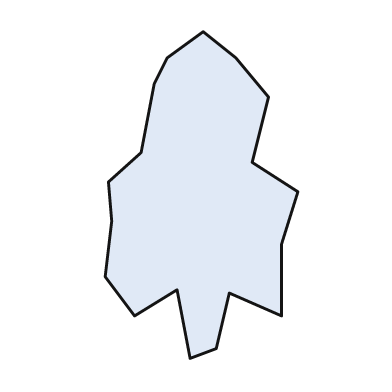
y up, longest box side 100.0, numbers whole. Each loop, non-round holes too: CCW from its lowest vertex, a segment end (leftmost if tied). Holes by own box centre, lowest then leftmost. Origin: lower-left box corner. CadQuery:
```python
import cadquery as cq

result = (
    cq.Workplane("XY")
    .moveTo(26.0, 0.0)
    .lineTo(34.0, 3.0)
    .lineTo(38.0, 20.0)
    .lineTo(54.0, 13.0)
    .lineTo(54.0, 35.0)
    .lineTo(59.0, 51.0)
    .lineTo(45.0, 60.0)
    .lineTo(50.0, 80.0)
    .lineTo(40.0, 92.0)
    .lineTo(30.0, 100.0)
    .lineTo(19.0, 92.0)
    .lineTo(15.0, 84.0)
    .lineTo(11.0, 63.0)
    .lineTo(1.0, 54.0)
    .lineTo(2.0, 42.0)
    .lineTo(0.0, 25.0)
    .lineTo(9.0, 13.0)
    .lineTo(22.0, 21.0)
    .close()
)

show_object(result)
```